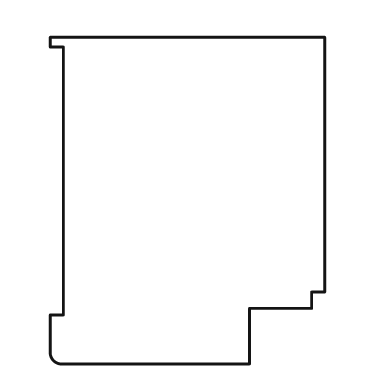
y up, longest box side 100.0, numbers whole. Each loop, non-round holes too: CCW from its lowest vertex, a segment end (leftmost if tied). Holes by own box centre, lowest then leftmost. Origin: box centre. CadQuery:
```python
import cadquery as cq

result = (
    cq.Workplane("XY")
    .moveTo(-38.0, -50.0)
    .lineTo(19.0, -50.0)
    .lineTo(19.0, -33.0)
    .lineTo(38.0, -33.0)
    .lineTo(38.0, -28.0)
    .lineTo(42.0, -28.0)
    .lineTo(42.0, 50.0)
    .lineTo(-42.0, 50.0)
    .lineTo(-42.0, 47.0)
    .lineTo(-38.0, 47.0)
    .lineTo(-38.0, -35.0)
    .lineTo(-42.0, -35.0)
    .lineTo(-42.0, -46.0)
    .threePointArc((-41.0, -49.0), (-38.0, -50.0))
    .close()
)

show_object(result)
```